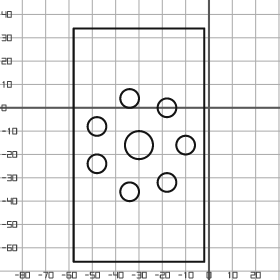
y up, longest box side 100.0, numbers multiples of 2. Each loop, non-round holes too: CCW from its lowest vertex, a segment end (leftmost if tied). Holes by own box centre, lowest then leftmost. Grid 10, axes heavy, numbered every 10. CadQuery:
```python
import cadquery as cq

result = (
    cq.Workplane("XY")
    .moveTo(-58.0, -66.0)
    .lineTo(-2.0, -66.0)
    .lineTo(-2.0, 34.0)
    .lineTo(-58.0, 34.0)
    .close()
    .moveTo(-34.0, -36.0)
    .circle(4.0)
    .moveTo(-18.0, -32.0)
    .circle(4.0)
    .moveTo(-48.0, -24.0)
    .circle(4.0)
    .moveTo(-30.0, -16.0)
    .circle(6.0)
    .moveTo(-10.0, -16.0)
    .circle(4.0)
    .moveTo(-48.0, -8.0)
    .circle(4.0)
    .moveTo(-18.0, 0.0)
    .circle(4.0)
    .moveTo(-34.0, 4.0)
    .circle(4.0)
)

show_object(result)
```